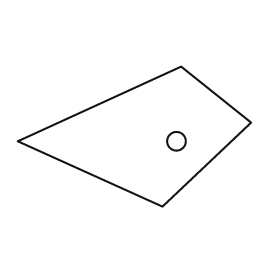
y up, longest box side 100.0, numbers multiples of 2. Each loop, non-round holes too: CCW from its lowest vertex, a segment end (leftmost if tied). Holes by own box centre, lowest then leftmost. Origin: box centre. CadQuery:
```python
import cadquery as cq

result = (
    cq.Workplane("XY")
    .moveTo(12.0, -30.0)
    .lineTo(50.0, 6.0)
    .lineTo(20.0, 30.0)
    .lineTo(-50.0, -2.0)
    .close()
    .moveTo(18.0, -2.0)
    .circle(4.0)
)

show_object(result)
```